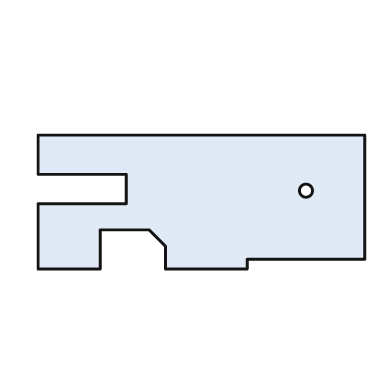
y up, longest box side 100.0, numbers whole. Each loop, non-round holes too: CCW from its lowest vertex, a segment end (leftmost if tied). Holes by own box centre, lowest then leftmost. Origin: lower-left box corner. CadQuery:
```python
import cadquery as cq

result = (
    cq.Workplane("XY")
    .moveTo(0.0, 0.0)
    .lineTo(19.0, 0.0)
    .lineTo(19.0, 12.0)
    .lineTo(34.0, 12.0)
    .lineTo(39.0, 7.0)
    .lineTo(39.0, 0.0)
    .lineTo(64.0, 0.0)
    .lineTo(64.0, 3.0)
    .lineTo(100.0, 3.0)
    .lineTo(100.0, 41.0)
    .lineTo(0.0, 41.0)
    .lineTo(0.0, 29.0)
    .lineTo(27.0, 29.0)
    .lineTo(27.0, 20.0)
    .lineTo(0.0, 20.0)
    .close()
    .moveTo(82.0, 24.0)
    .circle(2.0)
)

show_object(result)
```